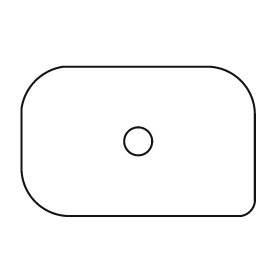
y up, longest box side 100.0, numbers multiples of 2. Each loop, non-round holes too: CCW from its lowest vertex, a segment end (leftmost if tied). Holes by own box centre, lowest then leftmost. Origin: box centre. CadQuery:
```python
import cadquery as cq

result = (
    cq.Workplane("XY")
    .moveTo(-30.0, -32.0)
    .lineTo(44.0, -32.0)
    .threePointArc((48.0, -30.0), (50.0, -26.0))
    .lineTo(50.0, 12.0)
    .threePointArc((44.0, 26.0), (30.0, 32.0))
    .lineTo(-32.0, 32.0)
    .threePointArc((-44.0, 26.0), (-50.0, 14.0))
    .lineTo(-50.0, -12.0)
    .threePointArc((-44.0, -26.0), (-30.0, -32.0))
    .close()
    .moveTo(0.0, 0.0)
    .circle(6.0)
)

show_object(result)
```